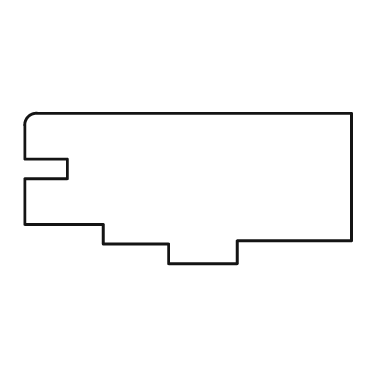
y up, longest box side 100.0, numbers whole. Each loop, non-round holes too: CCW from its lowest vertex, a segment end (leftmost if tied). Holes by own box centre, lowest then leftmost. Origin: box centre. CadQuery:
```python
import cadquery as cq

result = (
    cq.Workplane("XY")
    .moveTo(-6.0, -23.0)
    .lineTo(15.0, -23.0)
    .lineTo(15.0, -16.0)
    .lineTo(50.0, -16.0)
    .lineTo(50.0, 23.0)
    .lineTo(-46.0, 23.0)
    .threePointArc((-49.0, 22.0), (-50.0, 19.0))
    .lineTo(-50.0, 9.0)
    .lineTo(-37.0, 9.0)
    .lineTo(-37.0, 3.0)
    .lineTo(-50.0, 3.0)
    .lineTo(-50.0, -11.0)
    .lineTo(-26.0, -11.0)
    .lineTo(-26.0, -17.0)
    .lineTo(-6.0, -17.0)
    .close()
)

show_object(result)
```